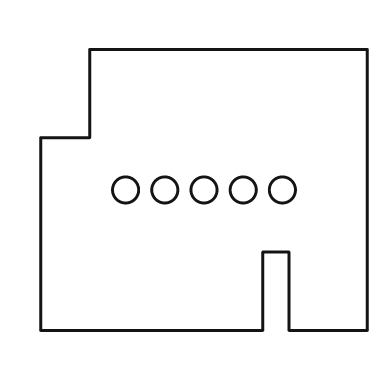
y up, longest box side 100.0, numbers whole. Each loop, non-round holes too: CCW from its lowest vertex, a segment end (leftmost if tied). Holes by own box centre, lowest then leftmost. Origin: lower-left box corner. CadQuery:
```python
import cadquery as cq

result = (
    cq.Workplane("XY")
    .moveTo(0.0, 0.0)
    .lineTo(68.0, 0.0)
    .lineTo(68.0, 24.0)
    .lineTo(76.0, 24.0)
    .lineTo(76.0, 0.0)
    .lineTo(100.0, 0.0)
    .lineTo(100.0, 86.0)
    .lineTo(15.0, 86.0)
    .lineTo(15.0, 59.0)
    .lineTo(0.0, 59.0)
    .close()
    .moveTo(26.0, 43.0)
    .circle(4.0)
    .moveTo(38.0, 43.0)
    .circle(4.0)
    .moveTo(50.0, 43.0)
    .circle(4.0)
    .moveTo(62.0, 43.0)
    .circle(4.0)
    .moveTo(74.0, 43.0)
    .circle(4.0)
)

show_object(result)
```